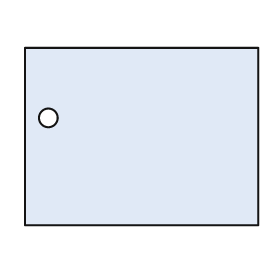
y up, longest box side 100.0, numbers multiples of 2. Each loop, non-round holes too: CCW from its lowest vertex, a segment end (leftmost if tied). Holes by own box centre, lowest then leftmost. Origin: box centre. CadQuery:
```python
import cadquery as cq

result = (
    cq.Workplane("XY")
    .moveTo(-50.0, -38.0)
    .lineTo(50.0, -38.0)
    .lineTo(50.0, 38.0)
    .lineTo(-50.0, 38.0)
    .close()
    .moveTo(-40.0, 8.0)
    .circle(4.0)
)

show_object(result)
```